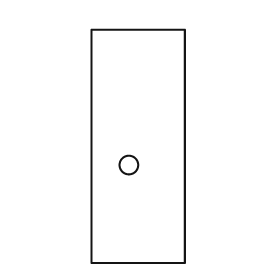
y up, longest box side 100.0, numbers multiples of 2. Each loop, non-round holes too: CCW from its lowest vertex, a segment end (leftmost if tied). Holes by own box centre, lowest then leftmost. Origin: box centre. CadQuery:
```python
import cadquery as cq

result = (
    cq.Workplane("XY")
    .moveTo(-20.0, -50.0)
    .lineTo(20.0, -50.0)
    .lineTo(20.0, 50.0)
    .lineTo(-20.0, 50.0)
    .close()
    .moveTo(-4.0, -8.0)
    .circle(4.0)
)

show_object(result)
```